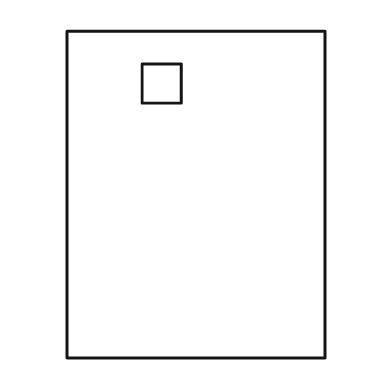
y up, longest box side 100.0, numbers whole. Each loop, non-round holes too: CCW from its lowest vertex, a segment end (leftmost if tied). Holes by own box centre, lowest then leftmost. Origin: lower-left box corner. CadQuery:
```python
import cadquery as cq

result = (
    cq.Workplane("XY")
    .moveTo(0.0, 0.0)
    .lineTo(79.0, 0.0)
    .lineTo(79.0, 100.0)
    .lineTo(0.0, 100.0)
    .close()
    .moveTo(23.0, 78.0)
    .lineTo(35.0, 78.0)
    .lineTo(35.0, 90.0)
    .lineTo(23.0, 90.0)
    .close()
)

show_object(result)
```